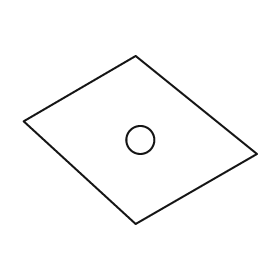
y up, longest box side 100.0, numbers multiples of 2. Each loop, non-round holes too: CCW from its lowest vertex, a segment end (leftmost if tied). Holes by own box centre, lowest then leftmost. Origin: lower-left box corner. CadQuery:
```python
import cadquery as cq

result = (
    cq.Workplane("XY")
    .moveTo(48.0, 0.0)
    .lineTo(100.0, 30.0)
    .lineTo(48.0, 72.0)
    .lineTo(0.0, 44.0)
    .close()
    .moveTo(50.0, 36.0)
    .circle(6.0)
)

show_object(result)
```